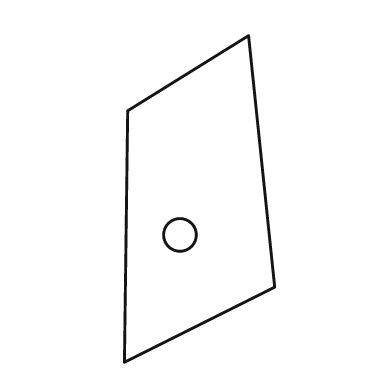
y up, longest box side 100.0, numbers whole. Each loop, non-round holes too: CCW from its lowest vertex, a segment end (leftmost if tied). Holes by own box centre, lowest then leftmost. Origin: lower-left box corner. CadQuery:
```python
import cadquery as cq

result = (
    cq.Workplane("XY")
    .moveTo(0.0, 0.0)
    .lineTo(46.0, 23.0)
    .lineTo(38.0, 100.0)
    .lineTo(1.0, 77.0)
    .close()
    .moveTo(17.0, 39.0)
    .circle(5.0)
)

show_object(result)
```